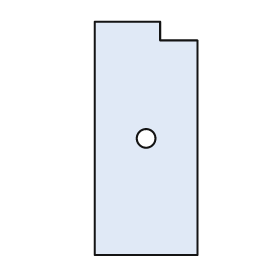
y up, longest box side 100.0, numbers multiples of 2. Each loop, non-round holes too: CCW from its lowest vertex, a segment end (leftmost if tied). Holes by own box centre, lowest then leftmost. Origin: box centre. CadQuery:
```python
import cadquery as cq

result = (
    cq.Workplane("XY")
    .moveTo(-22.0, -50.0)
    .lineTo(22.0, -50.0)
    .lineTo(22.0, 42.0)
    .lineTo(6.0, 42.0)
    .lineTo(6.0, 50.0)
    .lineTo(-22.0, 50.0)
    .close()
    .moveTo(0.0, 0.0)
    .circle(4.0)
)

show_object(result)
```